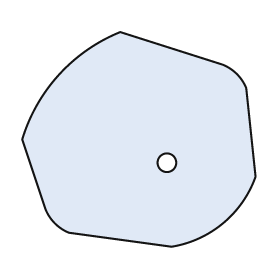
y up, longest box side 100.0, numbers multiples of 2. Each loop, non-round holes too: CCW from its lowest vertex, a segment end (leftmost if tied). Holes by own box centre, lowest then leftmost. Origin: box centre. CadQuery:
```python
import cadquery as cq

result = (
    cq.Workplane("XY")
    .moveTo(14.0, -46.0)
    .threePointArc((36.0, -36.0), (50.0, -16.0))
    .lineTo(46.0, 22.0)
    .threePointArc((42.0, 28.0), (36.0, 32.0))
    .lineTo(-8.0, 46.0)
    .threePointArc((-34.0, 28.0), (-50.0, 0.0))
    .lineTo(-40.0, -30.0)
    .threePointArc((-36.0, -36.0), (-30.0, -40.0))
    .close()
    .moveTo(12.0, -10.0)
    .circle(4.0)
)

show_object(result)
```